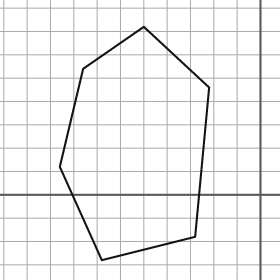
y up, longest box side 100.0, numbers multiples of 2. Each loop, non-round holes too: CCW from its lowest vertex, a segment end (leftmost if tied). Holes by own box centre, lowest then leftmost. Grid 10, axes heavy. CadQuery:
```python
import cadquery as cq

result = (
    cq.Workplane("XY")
    .moveTo(-68.0, -28.0)
    .lineTo(-28.0, -18.0)
    .lineTo(-22.0, 46.0)
    .lineTo(-50.0, 72.0)
    .lineTo(-76.0, 54.0)
    .lineTo(-86.0, 12.0)
    .close()
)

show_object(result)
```